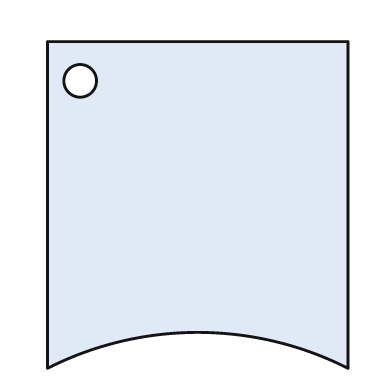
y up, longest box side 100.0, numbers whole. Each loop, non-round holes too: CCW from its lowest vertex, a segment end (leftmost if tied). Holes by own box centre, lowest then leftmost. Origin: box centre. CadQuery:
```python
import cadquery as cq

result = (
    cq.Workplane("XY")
    .moveTo(-46.0, -50.0)
    .threePointArc((0.0, -39.0), (46.0, -50.0))
    .lineTo(46.0, 50.0)
    .lineTo(-46.0, 50.0)
    .close()
    .moveTo(-36.0, 38.0)
    .circle(5.0)
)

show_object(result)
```